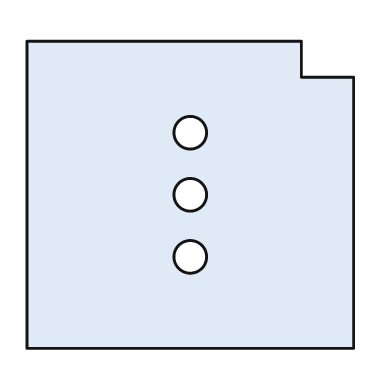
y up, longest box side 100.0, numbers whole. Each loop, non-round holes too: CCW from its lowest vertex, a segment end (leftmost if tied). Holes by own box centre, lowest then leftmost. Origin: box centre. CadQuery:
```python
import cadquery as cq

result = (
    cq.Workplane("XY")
    .moveTo(-50.0, -47.0)
    .lineTo(50.0, -47.0)
    .lineTo(50.0, 36.0)
    .lineTo(34.0, 36.0)
    .lineTo(34.0, 47.0)
    .lineTo(-50.0, 47.0)
    .close()
    .moveTo(0.0, -19.0)
    .circle(5.0)
    .moveTo(0.0, 0.0)
    .circle(5.0)
    .moveTo(0.0, 19.0)
    .circle(5.0)
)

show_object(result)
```